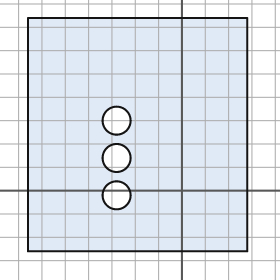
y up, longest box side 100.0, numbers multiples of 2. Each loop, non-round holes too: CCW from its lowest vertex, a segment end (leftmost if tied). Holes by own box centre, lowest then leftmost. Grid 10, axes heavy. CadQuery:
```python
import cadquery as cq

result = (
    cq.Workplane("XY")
    .moveTo(-66.0, -26.0)
    .lineTo(28.0, -26.0)
    .lineTo(28.0, 74.0)
    .lineTo(-66.0, 74.0)
    .close()
    .moveTo(-28.0, -2.0)
    .circle(6.0)
    .moveTo(-28.0, 14.0)
    .circle(6.0)
    .moveTo(-28.0, 30.0)
    .circle(6.0)
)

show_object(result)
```